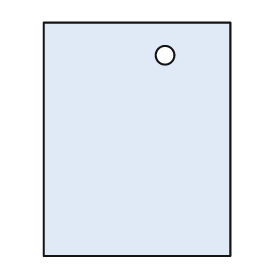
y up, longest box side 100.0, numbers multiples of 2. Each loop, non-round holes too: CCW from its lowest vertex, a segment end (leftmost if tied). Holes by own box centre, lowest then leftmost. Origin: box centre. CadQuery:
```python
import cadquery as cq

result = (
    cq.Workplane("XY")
    .moveTo(-40.0, -50.0)
    .lineTo(40.0, -50.0)
    .lineTo(40.0, 50.0)
    .lineTo(-40.0, 50.0)
    .close()
    .moveTo(12.0, 36.0)
    .circle(4.0)
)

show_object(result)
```